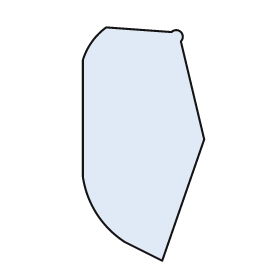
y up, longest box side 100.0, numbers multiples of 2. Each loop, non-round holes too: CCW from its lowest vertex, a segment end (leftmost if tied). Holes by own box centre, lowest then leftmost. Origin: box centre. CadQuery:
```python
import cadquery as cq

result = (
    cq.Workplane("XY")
    .moveTo(8.0, -50.0)
    .lineTo(26.0, 2.0)
    .lineTo(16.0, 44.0)
    .threePointArc((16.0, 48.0), (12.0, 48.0))
    .lineTo(-16.0, 50.0)
    .threePointArc((-22.0, 44.0), (-26.0, 36.0))
    .lineTo(-26.0, -14.0)
    .threePointArc((-20.0, -30.0), (-8.0, -42.0))
    .close()
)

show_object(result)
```